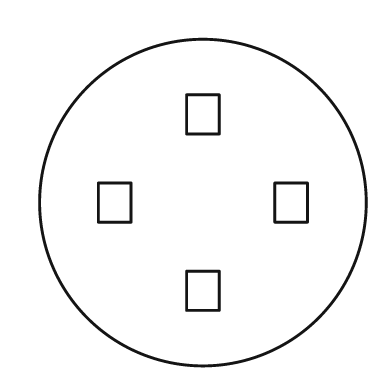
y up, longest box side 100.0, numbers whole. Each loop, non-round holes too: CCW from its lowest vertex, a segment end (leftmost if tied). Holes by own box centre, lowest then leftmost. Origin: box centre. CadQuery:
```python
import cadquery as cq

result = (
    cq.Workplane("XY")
    .moveTo(0.0, 0.0)
    .circle(50.0)
    .moveTo(-5.0, -33.0)
    .lineTo(5.0, -33.0)
    .lineTo(5.0, -21.0)
    .lineTo(-5.0, -21.0)
    .close()
    .moveTo(-32.0, -6.0)
    .lineTo(-22.0, -6.0)
    .lineTo(-22.0, 6.0)
    .lineTo(-32.0, 6.0)
    .close()
    .moveTo(22.0, -6.0)
    .lineTo(32.0, -6.0)
    .lineTo(32.0, 6.0)
    .lineTo(22.0, 6.0)
    .close()
    .moveTo(-5.0, 21.0)
    .lineTo(5.0, 21.0)
    .lineTo(5.0, 33.0)
    .lineTo(-5.0, 33.0)
    .close()
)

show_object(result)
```